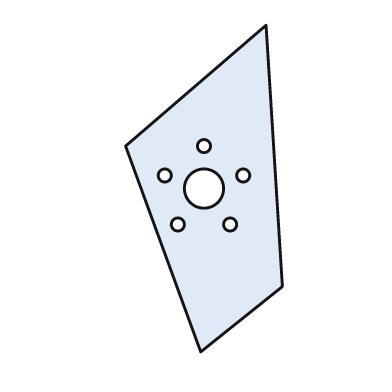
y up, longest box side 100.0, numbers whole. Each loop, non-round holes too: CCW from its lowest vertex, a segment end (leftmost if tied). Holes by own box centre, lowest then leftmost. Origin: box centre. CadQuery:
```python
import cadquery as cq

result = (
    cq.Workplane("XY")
    .moveTo(-1.0, -50.0)
    .lineTo(24.0, -30.0)
    .lineTo(19.0, 50.0)
    .lineTo(-24.0, 13.0)
    .close()
    .moveTo(-8.0, -11.0)
    .circle(2.0)
    .moveTo(8.0, -11.0)
    .circle(2.0)
    .moveTo(0.0, 0.0)
    .circle(6.0)
    .moveTo(-12.0, 4.0)
    .circle(2.0)
    .moveTo(12.0, 4.0)
    .circle(2.0)
    .moveTo(0.0, 13.0)
    .circle(2.0)
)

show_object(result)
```